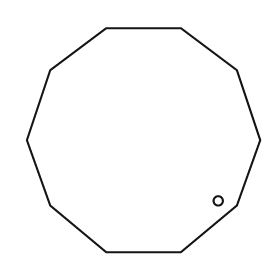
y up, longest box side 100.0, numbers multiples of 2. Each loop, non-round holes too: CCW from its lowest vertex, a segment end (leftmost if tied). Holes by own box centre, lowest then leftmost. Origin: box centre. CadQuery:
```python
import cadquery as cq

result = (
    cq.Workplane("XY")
    .moveTo(-16.0, -48.0)
    .lineTo(16.0, -48.0)
    .lineTo(40.0, -28.0)
    .lineTo(50.0, 0.0)
    .lineTo(40.0, 30.0)
    .lineTo(16.0, 48.0)
    .lineTo(-16.0, 48.0)
    .lineTo(-40.0, 30.0)
    .lineTo(-50.0, 0.0)
    .lineTo(-40.0, -28.0)
    .close()
    .moveTo(32.0, -26.0)
    .circle(2.0)
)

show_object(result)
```